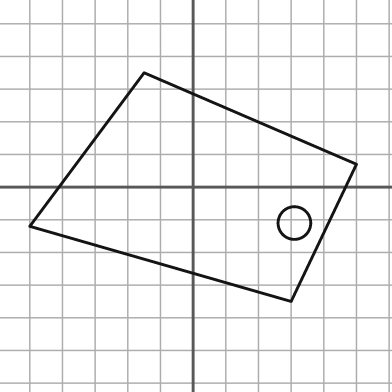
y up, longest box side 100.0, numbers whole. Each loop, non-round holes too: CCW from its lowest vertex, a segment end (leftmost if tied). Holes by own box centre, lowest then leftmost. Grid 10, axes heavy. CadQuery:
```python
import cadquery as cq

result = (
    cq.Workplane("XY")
    .moveTo(30.0, -35.0)
    .lineTo(50.0, 7.0)
    .lineTo(-15.0, 35.0)
    .lineTo(-50.0, -12.0)
    .close()
    .moveTo(31.0, -11.0)
    .circle(5.0)
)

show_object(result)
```